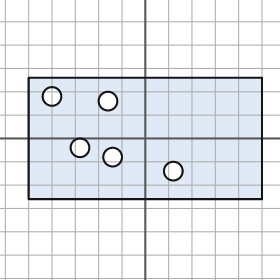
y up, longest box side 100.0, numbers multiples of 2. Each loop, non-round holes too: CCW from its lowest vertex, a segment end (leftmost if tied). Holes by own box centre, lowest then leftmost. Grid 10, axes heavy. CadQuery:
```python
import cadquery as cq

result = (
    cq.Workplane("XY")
    .moveTo(-50.0, -26.0)
    .lineTo(50.0, -26.0)
    .lineTo(50.0, 26.0)
    .lineTo(-50.0, 26.0)
    .close()
    .moveTo(12.0, -14.0)
    .circle(4.0)
    .moveTo(-14.0, -8.0)
    .circle(4.0)
    .moveTo(-28.0, -4.0)
    .circle(4.0)
    .moveTo(-16.0, 16.0)
    .circle(4.0)
    .moveTo(-40.0, 18.0)
    .circle(4.0)
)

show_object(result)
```